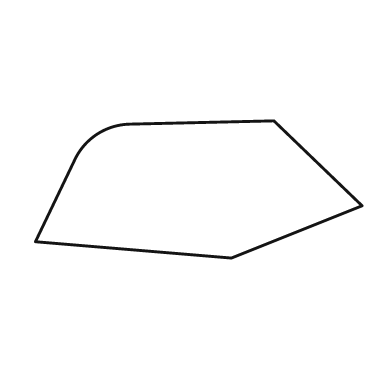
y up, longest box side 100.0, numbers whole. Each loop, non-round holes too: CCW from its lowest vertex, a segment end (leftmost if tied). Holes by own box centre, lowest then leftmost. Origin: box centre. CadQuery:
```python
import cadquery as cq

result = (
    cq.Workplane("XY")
    .moveTo(10.0, -21.0)
    .lineTo(50.0, -5.0)
    .lineTo(23.0, 21.0)
    .lineTo(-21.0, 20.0)
    .threePointArc((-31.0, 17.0), (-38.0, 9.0))
    .lineTo(-50.0, -16.0)
    .close()
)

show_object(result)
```